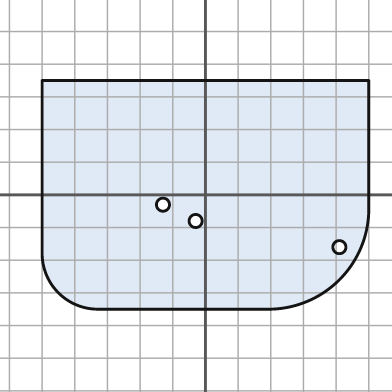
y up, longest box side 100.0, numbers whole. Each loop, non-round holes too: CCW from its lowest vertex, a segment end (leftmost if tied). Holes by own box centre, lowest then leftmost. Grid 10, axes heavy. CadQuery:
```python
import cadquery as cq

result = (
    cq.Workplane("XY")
    .moveTo(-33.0, -35.0)
    .lineTo(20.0, -35.0)
    .threePointArc((41.0, -26.0), (50.0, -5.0))
    .lineTo(50.0, 35.0)
    .lineTo(-50.0, 35.0)
    .lineTo(-50.0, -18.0)
    .threePointArc((-45.0, -30.0), (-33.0, -35.0))
    .close()
    .moveTo(41.0, -16.0)
    .circle(2.0)
    .moveTo(-3.0, -8.0)
    .circle(2.0)
    .moveTo(-13.0, -3.0)
    .circle(2.0)
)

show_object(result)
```